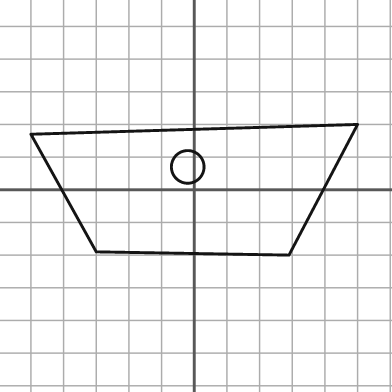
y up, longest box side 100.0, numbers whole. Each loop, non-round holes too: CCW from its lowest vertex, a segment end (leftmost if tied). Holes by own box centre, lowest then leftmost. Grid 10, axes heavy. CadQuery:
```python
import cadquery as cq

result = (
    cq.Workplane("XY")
    .moveTo(29.0, -20.0)
    .lineTo(50.0, 20.0)
    .lineTo(-50.0, 17.0)
    .lineTo(-30.0, -19.0)
    .close()
    .moveTo(-2.0, 7.0)
    .circle(5.0)
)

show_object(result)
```